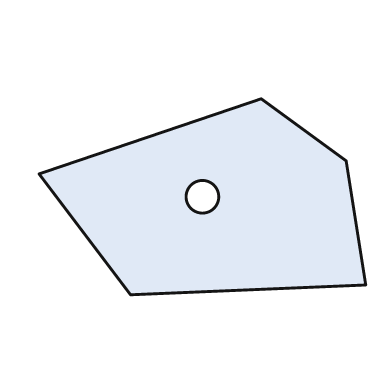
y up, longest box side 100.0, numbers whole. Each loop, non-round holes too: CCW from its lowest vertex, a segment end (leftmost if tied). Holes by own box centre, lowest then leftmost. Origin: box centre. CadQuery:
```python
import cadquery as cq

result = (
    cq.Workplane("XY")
    .moveTo(-22.0, -30.0)
    .lineTo(50.0, -27.0)
    .lineTo(44.0, 11.0)
    .lineTo(18.0, 30.0)
    .lineTo(-50.0, 7.0)
    .close()
    .moveTo(0.0, 0.0)
    .circle(5.0)
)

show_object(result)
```